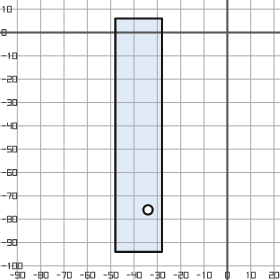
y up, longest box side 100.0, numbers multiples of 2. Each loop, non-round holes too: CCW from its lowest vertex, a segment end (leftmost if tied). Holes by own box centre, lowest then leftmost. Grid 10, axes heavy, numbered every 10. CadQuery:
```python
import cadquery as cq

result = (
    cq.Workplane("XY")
    .moveTo(-48.0, -94.0)
    .lineTo(-28.0, -94.0)
    .lineTo(-28.0, 6.0)
    .lineTo(-48.0, 6.0)
    .close()
    .moveTo(-34.0, -76.0)
    .circle(2.0)
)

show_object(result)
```